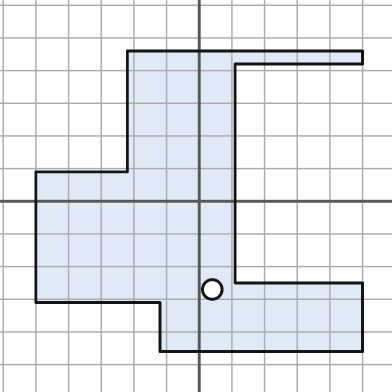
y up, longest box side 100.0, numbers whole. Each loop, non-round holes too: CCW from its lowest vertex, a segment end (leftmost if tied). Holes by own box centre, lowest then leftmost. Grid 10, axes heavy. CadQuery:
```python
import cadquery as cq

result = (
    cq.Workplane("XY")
    .moveTo(-12.0, -46.0)
    .lineTo(50.0, -46.0)
    .lineTo(50.0, -25.0)
    .lineTo(11.0, -25.0)
    .lineTo(11.0, 42.0)
    .lineTo(50.0, 42.0)
    .lineTo(50.0, 46.0)
    .lineTo(-22.0, 46.0)
    .lineTo(-22.0, 9.0)
    .lineTo(-50.0, 9.0)
    .lineTo(-50.0, -31.0)
    .lineTo(-12.0, -31.0)
    .close()
    .moveTo(4.0, -27.0)
    .circle(3.0)
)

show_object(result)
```